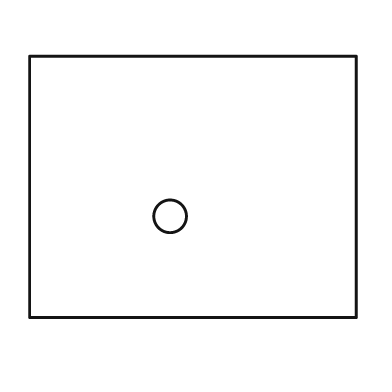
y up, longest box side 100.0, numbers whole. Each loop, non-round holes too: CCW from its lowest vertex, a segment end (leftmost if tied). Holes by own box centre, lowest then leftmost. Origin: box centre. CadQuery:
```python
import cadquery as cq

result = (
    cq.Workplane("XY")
    .moveTo(-50.0, -40.0)
    .lineTo(50.0, -40.0)
    .lineTo(50.0, 40.0)
    .lineTo(-50.0, 40.0)
    .close()
    .moveTo(-7.0, -9.0)
    .circle(5.0)
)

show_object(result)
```